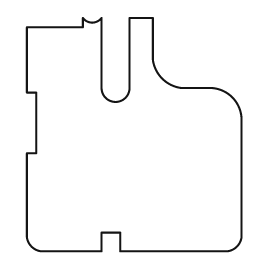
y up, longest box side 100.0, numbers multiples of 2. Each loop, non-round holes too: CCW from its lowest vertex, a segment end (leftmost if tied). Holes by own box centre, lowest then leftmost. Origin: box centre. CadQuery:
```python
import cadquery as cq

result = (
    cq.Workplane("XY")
    .moveTo(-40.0, -50.0)
    .lineTo(-14.0, -50.0)
    .lineTo(-14.0, -42.0)
    .lineTo(-6.0, -42.0)
    .lineTo(-6.0, -50.0)
    .lineTo(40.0, -50.0)
    .threePointArc((44.0, -48.0), (46.0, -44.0))
    .lineTo(46.0, 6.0)
    .threePointArc((42.0, 16.0), (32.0, 20.0))
    .lineTo(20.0, 20.0)
    .threePointArc((12.0, 24.0), (8.0, 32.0))
    .lineTo(8.0, 50.0)
    .lineTo(-2.0, 50.0)
    .lineTo(-2.0, 20.0)
    .threePointArc((-8.0, 14.0), (-14.0, 20.0))
    .lineTo(-14.0, 50.0)
    .threePointArc((-18.0, 48.0), (-22.0, 50.0))
    .lineTo(-22.0, 46.0)
    .lineTo(-46.0, 46.0)
    .lineTo(-46.0, 18.0)
    .lineTo(-42.0, 18.0)
    .lineTo(-42.0, -8.0)
    .lineTo(-46.0, -8.0)
    .lineTo(-46.0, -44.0)
    .threePointArc((-44.0, -48.0), (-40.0, -50.0))
    .close()
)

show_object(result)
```